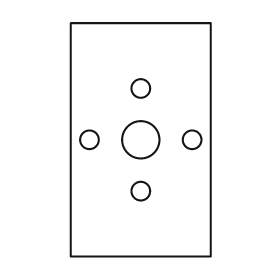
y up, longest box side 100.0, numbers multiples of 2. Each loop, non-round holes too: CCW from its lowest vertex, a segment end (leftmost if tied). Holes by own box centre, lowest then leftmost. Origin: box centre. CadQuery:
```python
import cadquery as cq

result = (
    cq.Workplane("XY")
    .moveTo(-30.0, -50.0)
    .lineTo(30.0, -50.0)
    .lineTo(30.0, 50.0)
    .lineTo(-30.0, 50.0)
    .close()
    .moveTo(0.0, -22.0)
    .circle(4.0)
    .moveTo(-22.0, 0.0)
    .circle(4.0)
    .moveTo(0.0, 0.0)
    .circle(8.0)
    .moveTo(22.0, 0.0)
    .circle(4.0)
    .moveTo(0.0, 22.0)
    .circle(4.0)
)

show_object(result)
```